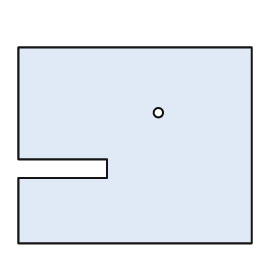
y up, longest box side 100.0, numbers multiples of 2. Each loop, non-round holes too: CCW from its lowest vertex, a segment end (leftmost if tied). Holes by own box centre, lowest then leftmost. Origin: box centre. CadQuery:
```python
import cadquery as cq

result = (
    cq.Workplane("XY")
    .moveTo(-50.0, -42.0)
    .lineTo(50.0, -42.0)
    .lineTo(50.0, 42.0)
    .lineTo(-50.0, 42.0)
    .lineTo(-50.0, -6.0)
    .lineTo(-12.0, -6.0)
    .lineTo(-12.0, -14.0)
    .lineTo(-50.0, -14.0)
    .close()
    .moveTo(10.0, 14.0)
    .circle(2.0)
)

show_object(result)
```